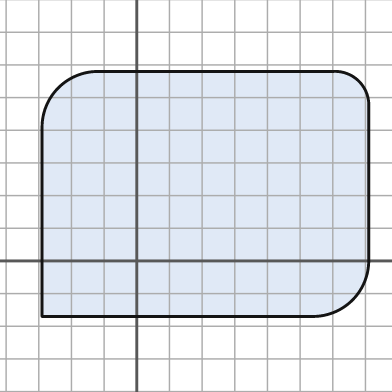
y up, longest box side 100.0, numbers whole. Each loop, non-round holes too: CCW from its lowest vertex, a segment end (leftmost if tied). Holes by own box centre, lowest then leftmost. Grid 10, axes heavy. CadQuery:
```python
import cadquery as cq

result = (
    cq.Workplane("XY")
    .moveTo(-29.0, -17.0)
    .lineTo(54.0, -17.0)
    .threePointArc((66.0, -12.0), (71.0, 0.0))
    .lineTo(71.0, 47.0)
    .threePointArc((68.0, 55.0), (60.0, 58.0))
    .lineTo(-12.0, 58.0)
    .threePointArc((-24.0, 53.0), (-29.0, 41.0))
    .close()
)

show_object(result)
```